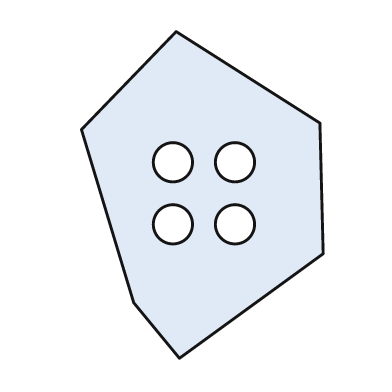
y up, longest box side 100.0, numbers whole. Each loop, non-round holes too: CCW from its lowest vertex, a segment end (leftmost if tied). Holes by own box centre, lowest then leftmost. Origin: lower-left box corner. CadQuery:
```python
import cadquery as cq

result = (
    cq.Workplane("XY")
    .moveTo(30.0, 0.0)
    .lineTo(74.0, 32.0)
    .lineTo(73.0, 72.0)
    .lineTo(29.0, 100.0)
    .lineTo(0.0, 70.0)
    .lineTo(16.0, 17.0)
    .close()
    .moveTo(28.0, 41.0)
    .circle(6.0)
    .moveTo(47.0, 41.0)
    .circle(6.0)
    .moveTo(28.0, 60.0)
    .circle(6.0)
    .moveTo(47.0, 60.0)
    .circle(6.0)
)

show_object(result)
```